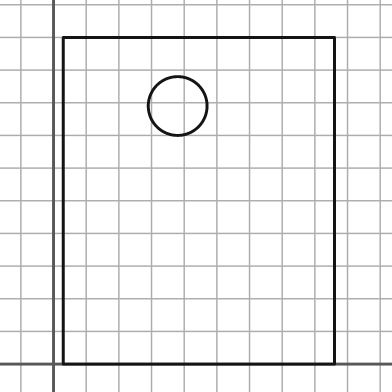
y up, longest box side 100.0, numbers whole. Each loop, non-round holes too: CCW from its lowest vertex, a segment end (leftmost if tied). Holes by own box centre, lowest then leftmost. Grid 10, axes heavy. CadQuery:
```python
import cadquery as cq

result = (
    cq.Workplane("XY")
    .moveTo(3.0, 0.0)
    .lineTo(86.0, 0.0)
    .lineTo(86.0, 100.0)
    .lineTo(3.0, 100.0)
    .close()
    .moveTo(38.0, 79.0)
    .circle(9.0)
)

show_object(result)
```